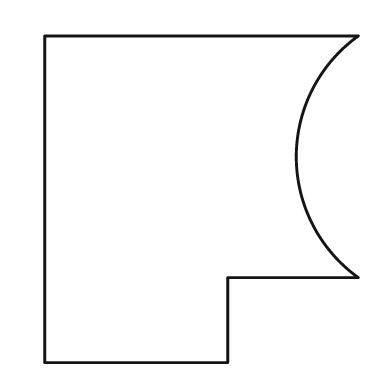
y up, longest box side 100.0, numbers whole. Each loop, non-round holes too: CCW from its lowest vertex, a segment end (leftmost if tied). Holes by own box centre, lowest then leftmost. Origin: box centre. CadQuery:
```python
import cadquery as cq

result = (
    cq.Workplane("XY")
    .moveTo(-48.0, -50.0)
    .lineTo(8.0, -50.0)
    .lineTo(8.0, -24.0)
    .lineTo(48.0, -24.0)
    .threePointArc((29.0, 13.0), (48.0, 50.0))
    .lineTo(-48.0, 50.0)
    .close()
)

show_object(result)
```